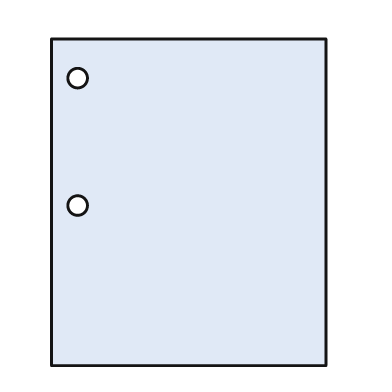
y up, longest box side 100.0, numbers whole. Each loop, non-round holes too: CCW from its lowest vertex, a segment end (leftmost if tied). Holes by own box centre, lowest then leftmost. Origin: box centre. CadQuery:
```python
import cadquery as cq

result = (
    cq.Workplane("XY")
    .moveTo(-42.0, -50.0)
    .lineTo(42.0, -50.0)
    .lineTo(42.0, 50.0)
    .lineTo(-42.0, 50.0)
    .close()
    .moveTo(-34.0, -1.0)
    .circle(3.0)
    .moveTo(-34.0, 38.0)
    .circle(3.0)
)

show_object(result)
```